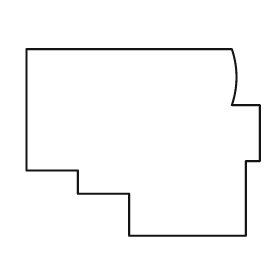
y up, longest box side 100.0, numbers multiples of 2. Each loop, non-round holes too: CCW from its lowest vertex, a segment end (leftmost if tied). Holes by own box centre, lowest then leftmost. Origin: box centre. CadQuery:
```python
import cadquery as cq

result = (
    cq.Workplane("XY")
    .moveTo(-6.0, -40.0)
    .lineTo(44.0, -40.0)
    .lineTo(44.0, -8.0)
    .lineTo(50.0, -8.0)
    .lineTo(50.0, 16.0)
    .lineTo(38.0, 16.0)
    .threePointArc((40.0, 28.0), (38.0, 40.0))
    .lineTo(-50.0, 40.0)
    .lineTo(-50.0, -12.0)
    .lineTo(-28.0, -12.0)
    .lineTo(-28.0, -22.0)
    .lineTo(-6.0, -22.0)
    .close()
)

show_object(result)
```